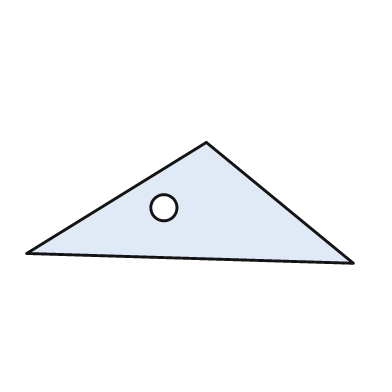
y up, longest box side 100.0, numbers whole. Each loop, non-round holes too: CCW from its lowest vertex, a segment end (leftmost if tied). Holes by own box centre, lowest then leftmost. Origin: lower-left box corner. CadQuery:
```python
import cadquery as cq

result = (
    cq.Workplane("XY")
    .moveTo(100.0, 0.0)
    .lineTo(55.0, 37.0)
    .lineTo(0.0, 3.0)
    .close()
    .moveTo(42.0, 17.0)
    .circle(4.0)
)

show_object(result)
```